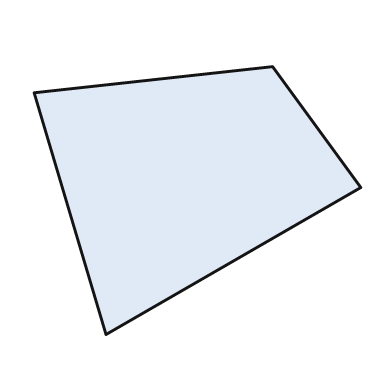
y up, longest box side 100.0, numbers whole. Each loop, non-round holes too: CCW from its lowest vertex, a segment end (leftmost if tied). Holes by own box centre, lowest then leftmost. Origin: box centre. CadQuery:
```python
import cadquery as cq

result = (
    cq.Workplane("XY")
    .moveTo(-28.0, -41.0)
    .lineTo(50.0, 4.0)
    .lineTo(23.0, 41.0)
    .lineTo(-50.0, 33.0)
    .close()
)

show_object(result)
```